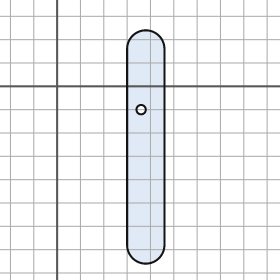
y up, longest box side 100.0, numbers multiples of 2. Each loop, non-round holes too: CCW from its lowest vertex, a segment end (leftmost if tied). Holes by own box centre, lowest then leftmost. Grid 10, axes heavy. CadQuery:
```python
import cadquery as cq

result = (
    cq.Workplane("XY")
    .moveTo(30.0, -68.0)
    .threePointArc((38.0, -76.0), (46.0, -68.0))
    .lineTo(46.0, 16.0)
    .threePointArc((38.0, 24.0), (30.0, 16.0))
    .close()
    .moveTo(36.0, -10.0)
    .circle(2.0)
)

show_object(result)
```